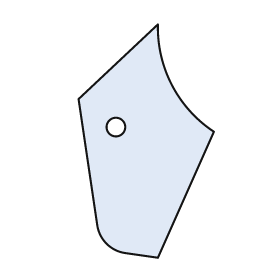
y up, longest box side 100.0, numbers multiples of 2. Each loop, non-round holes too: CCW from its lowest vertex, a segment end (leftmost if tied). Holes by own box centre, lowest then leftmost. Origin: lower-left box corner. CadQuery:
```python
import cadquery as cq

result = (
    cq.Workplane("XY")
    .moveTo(34.0, 0.0)
    .lineTo(58.0, 54.0)
    .threePointArc((40.0, 74.0), (34.0, 100.0))
    .lineTo(0.0, 68.0)
    .lineTo(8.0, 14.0)
    .threePointArc((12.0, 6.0), (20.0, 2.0))
    .close()
    .moveTo(16.0, 56.0)
    .circle(4.0)
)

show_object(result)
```